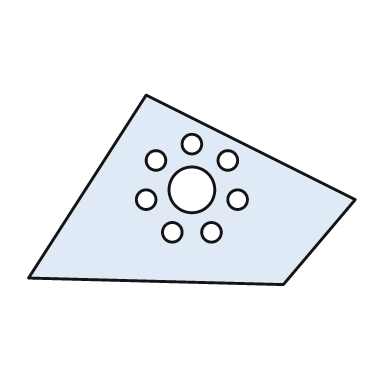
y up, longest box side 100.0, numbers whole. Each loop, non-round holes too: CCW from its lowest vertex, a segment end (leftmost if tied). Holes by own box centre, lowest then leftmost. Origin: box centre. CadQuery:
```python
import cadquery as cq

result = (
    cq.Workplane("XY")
    .moveTo(28.0, -29.0)
    .lineTo(50.0, -3.0)
    .lineTo(-14.0, 29.0)
    .lineTo(-50.0, -27.0)
    .close()
    .moveTo(-6.0, -13.0)
    .circle(3.0)
    .moveTo(6.0, -13.0)
    .circle(3.0)
    .moveTo(-14.0, -3.0)
    .circle(3.0)
    .moveTo(14.0, -3.0)
    .circle(3.0)
    .moveTo(0.0, 0.0)
    .circle(7.0)
    .moveTo(-11.0, 9.0)
    .circle(3.0)
    .moveTo(11.0, 9.0)
    .circle(3.0)
    .moveTo(0.0, 14.0)
    .circle(3.0)
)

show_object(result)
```